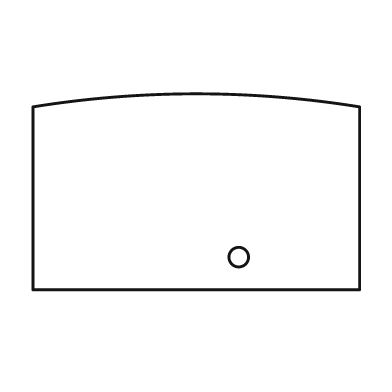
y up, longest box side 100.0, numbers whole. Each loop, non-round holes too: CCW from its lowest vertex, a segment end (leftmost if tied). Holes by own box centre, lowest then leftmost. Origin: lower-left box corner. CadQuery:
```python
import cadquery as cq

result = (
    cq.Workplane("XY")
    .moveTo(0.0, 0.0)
    .lineTo(100.0, 0.0)
    .lineTo(100.0, 56.0)
    .threePointArc((50.0, 60.0), (0.0, 56.0))
    .close()
    .moveTo(63.0, 10.0)
    .circle(3.0)
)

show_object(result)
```